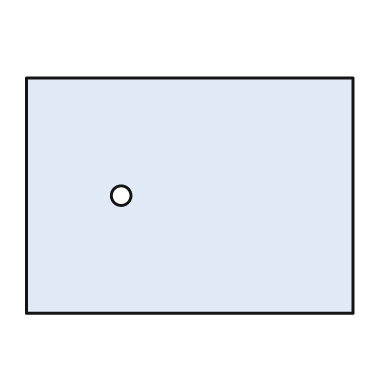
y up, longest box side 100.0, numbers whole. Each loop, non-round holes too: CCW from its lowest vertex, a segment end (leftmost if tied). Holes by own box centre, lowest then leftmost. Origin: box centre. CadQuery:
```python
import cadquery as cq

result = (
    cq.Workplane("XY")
    .moveTo(-50.0, -36.0)
    .lineTo(50.0, -36.0)
    .lineTo(50.0, 36.0)
    .lineTo(-50.0, 36.0)
    .close()
    .moveTo(-21.0, 0.0)
    .circle(3.0)
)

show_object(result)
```